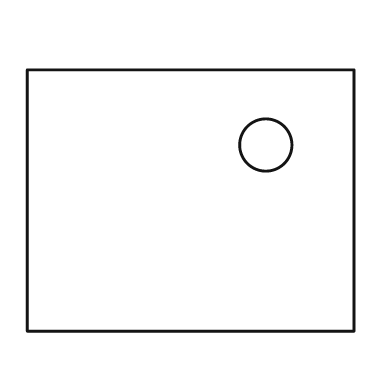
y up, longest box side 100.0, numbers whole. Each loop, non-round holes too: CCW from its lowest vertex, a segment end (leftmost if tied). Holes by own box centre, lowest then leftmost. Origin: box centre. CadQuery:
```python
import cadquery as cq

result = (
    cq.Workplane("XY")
    .moveTo(-50.0, -40.0)
    .lineTo(50.0, -40.0)
    .lineTo(50.0, 40.0)
    .lineTo(-50.0, 40.0)
    .close()
    .moveTo(23.0, 17.0)
    .circle(8.0)
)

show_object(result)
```